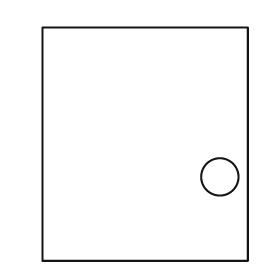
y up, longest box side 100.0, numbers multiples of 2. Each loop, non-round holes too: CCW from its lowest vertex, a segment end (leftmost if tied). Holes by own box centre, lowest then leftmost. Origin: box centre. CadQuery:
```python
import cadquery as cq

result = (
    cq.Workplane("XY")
    .moveTo(-44.0, -50.0)
    .lineTo(44.0, -50.0)
    .lineTo(44.0, 50.0)
    .lineTo(-44.0, 50.0)
    .close()
    .moveTo(32.0, -14.0)
    .circle(8.0)
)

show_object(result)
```